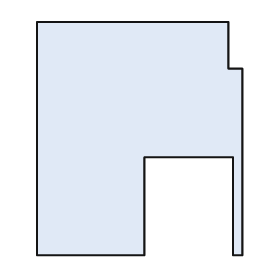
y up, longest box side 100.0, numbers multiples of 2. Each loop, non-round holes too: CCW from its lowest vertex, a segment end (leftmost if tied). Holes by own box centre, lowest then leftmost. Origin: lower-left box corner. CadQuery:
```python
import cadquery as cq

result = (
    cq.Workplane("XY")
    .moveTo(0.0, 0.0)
    .lineTo(46.0, 0.0)
    .lineTo(46.0, 42.0)
    .lineTo(84.0, 42.0)
    .lineTo(84.0, 0.0)
    .lineTo(88.0, 0.0)
    .lineTo(88.0, 80.0)
    .lineTo(82.0, 80.0)
    .lineTo(82.0, 100.0)
    .lineTo(0.0, 100.0)
    .close()
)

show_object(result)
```